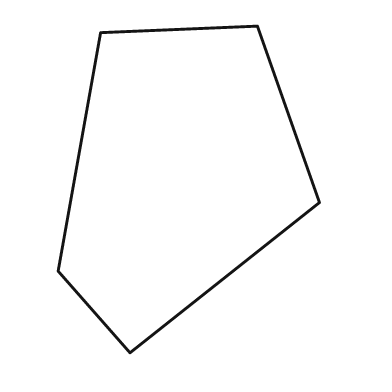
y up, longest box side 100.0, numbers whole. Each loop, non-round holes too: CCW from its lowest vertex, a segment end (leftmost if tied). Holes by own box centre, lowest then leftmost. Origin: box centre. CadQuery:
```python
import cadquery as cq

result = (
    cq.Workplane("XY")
    .moveTo(-18.0, -50.0)
    .lineTo(40.0, -4.0)
    .lineTo(21.0, 50.0)
    .lineTo(-27.0, 48.0)
    .lineTo(-40.0, -25.0)
    .close()
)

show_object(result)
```